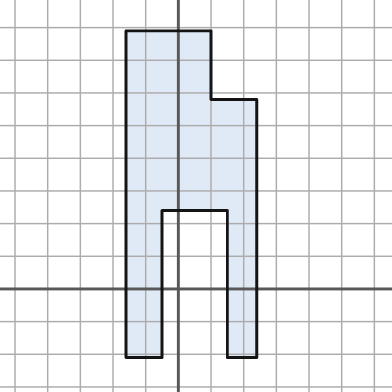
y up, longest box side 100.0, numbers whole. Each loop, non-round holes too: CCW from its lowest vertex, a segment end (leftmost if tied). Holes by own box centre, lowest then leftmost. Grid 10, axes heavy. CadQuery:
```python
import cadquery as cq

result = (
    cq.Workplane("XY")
    .moveTo(-16.0, -21.0)
    .lineTo(-5.0, -21.0)
    .lineTo(-5.0, 24.0)
    .lineTo(15.0, 24.0)
    .lineTo(15.0, -21.0)
    .lineTo(24.0, -21.0)
    .lineTo(24.0, 58.0)
    .lineTo(10.0, 58.0)
    .lineTo(10.0, 79.0)
    .lineTo(-16.0, 79.0)
    .close()
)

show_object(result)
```